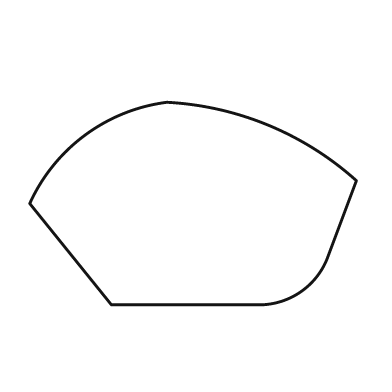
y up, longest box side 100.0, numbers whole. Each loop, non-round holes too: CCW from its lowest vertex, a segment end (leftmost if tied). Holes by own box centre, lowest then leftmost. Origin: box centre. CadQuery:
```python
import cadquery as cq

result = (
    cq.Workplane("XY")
    .moveTo(-25.0, -31.0)
    .lineTo(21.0, -31.0)
    .threePointArc((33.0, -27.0), (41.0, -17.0))
    .lineTo(50.0, 7.0)
    .threePointArc((23.0, 24.0), (-8.0, 31.0))
    .threePointArc((-33.0, 21.0), (-50.0, 0.0))
    .close()
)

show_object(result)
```